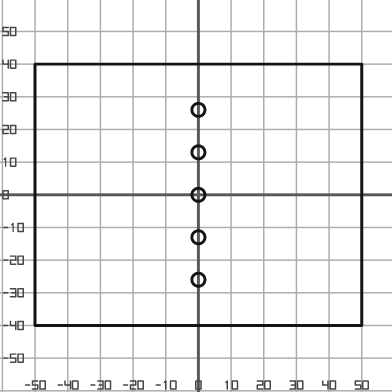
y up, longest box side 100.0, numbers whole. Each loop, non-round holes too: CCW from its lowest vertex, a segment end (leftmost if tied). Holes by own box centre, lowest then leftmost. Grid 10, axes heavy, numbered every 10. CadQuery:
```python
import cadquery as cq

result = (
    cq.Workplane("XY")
    .moveTo(-50.0, -40.0)
    .lineTo(50.0, -40.0)
    .lineTo(50.0, 40.0)
    .lineTo(-50.0, 40.0)
    .close()
    .moveTo(0.0, -26.0)
    .circle(2.0)
    .moveTo(0.0, -13.0)
    .circle(2.0)
    .moveTo(0.0, 0.0)
    .circle(2.0)
    .moveTo(0.0, 13.0)
    .circle(2.0)
    .moveTo(0.0, 26.0)
    .circle(2.0)
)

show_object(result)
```